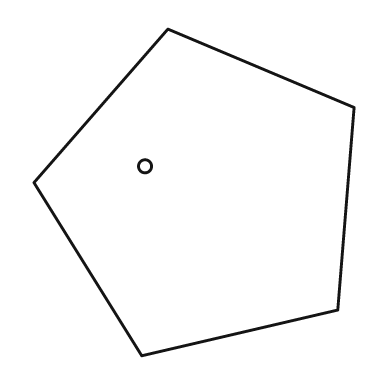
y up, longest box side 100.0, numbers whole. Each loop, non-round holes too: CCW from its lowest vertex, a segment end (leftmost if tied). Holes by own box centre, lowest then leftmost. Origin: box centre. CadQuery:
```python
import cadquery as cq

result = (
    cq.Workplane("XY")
    .moveTo(-16.0, -50.0)
    .lineTo(44.0, -36.0)
    .lineTo(49.0, 26.0)
    .lineTo(-8.0, 50.0)
    .lineTo(-49.0, 3.0)
    .close()
    .moveTo(-15.0, 8.0)
    .circle(2.0)
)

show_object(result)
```